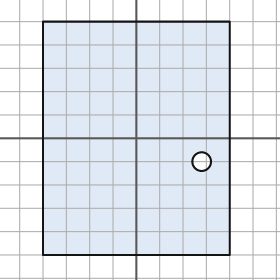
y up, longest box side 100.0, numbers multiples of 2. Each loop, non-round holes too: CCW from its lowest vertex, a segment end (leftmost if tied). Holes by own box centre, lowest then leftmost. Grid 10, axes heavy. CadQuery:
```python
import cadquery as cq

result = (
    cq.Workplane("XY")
    .moveTo(-40.0, -50.0)
    .lineTo(40.0, -50.0)
    .lineTo(40.0, 50.0)
    .lineTo(-40.0, 50.0)
    .close()
    .moveTo(28.0, -10.0)
    .circle(4.0)
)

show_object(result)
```